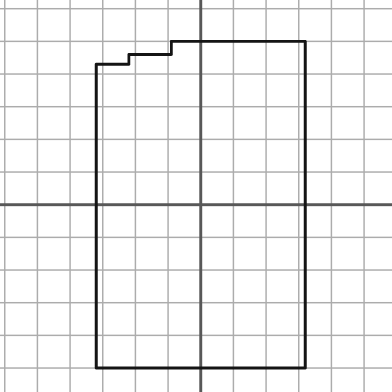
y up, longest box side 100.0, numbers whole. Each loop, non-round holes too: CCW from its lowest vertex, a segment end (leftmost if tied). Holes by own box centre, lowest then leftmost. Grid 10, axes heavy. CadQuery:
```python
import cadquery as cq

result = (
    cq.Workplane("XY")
    .moveTo(-32.0, -50.0)
    .lineTo(32.0, -50.0)
    .lineTo(32.0, 50.0)
    .lineTo(-9.0, 50.0)
    .lineTo(-9.0, 46.0)
    .lineTo(-22.0, 46.0)
    .lineTo(-22.0, 43.0)
    .lineTo(-32.0, 43.0)
    .close()
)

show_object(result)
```